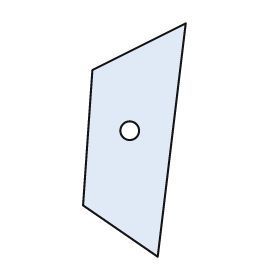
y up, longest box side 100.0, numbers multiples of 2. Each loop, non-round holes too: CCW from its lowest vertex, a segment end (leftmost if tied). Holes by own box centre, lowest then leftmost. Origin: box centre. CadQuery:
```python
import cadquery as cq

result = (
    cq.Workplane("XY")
    .moveTo(10.0, -50.0)
    .lineTo(22.0, 50.0)
    .lineTo(-18.0, 30.0)
    .lineTo(-22.0, -28.0)
    .close()
    .moveTo(-2.0, 4.0)
    .circle(4.0)
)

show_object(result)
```